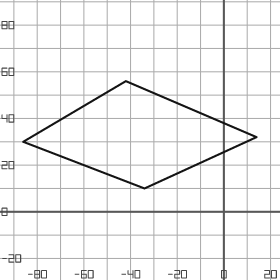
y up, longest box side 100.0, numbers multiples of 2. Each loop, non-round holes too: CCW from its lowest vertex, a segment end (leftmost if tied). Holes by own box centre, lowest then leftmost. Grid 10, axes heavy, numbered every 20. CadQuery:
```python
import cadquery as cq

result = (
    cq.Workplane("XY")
    .moveTo(-34.0, 10.0)
    .lineTo(14.0, 32.0)
    .lineTo(-42.0, 56.0)
    .lineTo(-86.0, 30.0)
    .close()
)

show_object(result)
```